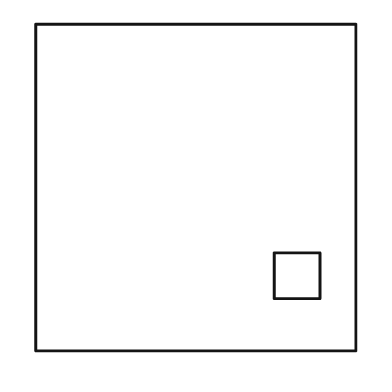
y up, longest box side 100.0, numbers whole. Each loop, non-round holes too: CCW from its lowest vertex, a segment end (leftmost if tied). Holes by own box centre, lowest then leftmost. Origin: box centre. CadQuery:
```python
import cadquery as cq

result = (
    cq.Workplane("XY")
    .moveTo(-49.0, -50.0)
    .lineTo(49.0, -50.0)
    .lineTo(49.0, 50.0)
    .lineTo(-49.0, 50.0)
    .close()
    .moveTo(24.0, -34.0)
    .lineTo(38.0, -34.0)
    .lineTo(38.0, -20.0)
    .lineTo(24.0, -20.0)
    .close()
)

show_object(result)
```